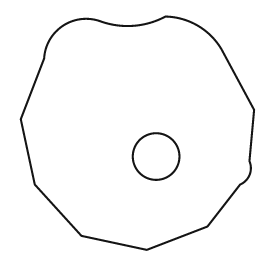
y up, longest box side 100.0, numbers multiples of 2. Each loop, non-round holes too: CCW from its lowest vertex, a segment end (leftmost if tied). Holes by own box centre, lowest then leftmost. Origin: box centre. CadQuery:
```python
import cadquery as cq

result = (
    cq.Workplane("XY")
    .moveTo(4.0, -50.0)
    .lineTo(30.0, -40.0)
    .lineTo(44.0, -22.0)
    .threePointArc((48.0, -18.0), (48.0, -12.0))
    .lineTo(50.0, 10.0)
    .lineTo(36.0, 36.0)
    .threePointArc((26.0, 46.0), (12.0, 50.0))
    .threePointArc((-2.0, 46.0), (-16.0, 48.0))
    .threePointArc((-32.0, 46.0), (-40.0, 32.0))
    .lineTo(-50.0, 6.0)
    .lineTo(-44.0, -22.0)
    .lineTo(-24.0, -44.0)
    .close()
    .moveTo(8.0, -10.0)
    .circle(10.0)
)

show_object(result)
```